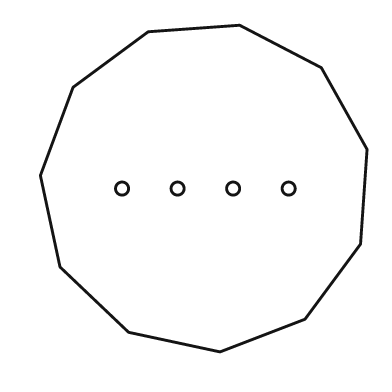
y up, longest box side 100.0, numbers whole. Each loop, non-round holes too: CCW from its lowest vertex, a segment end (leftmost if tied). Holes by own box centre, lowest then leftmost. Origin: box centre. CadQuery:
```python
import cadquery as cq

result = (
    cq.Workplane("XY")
    .moveTo(5.0, -50.0)
    .lineTo(31.0, -40.0)
    .lineTo(48.0, -17.0)
    .lineTo(50.0, 12.0)
    .lineTo(36.0, 37.0)
    .lineTo(11.0, 50.0)
    .lineTo(-17.0, 48.0)
    .lineTo(-40.0, 31.0)
    .lineTo(-50.0, 4.0)
    .lineTo(-44.0, -24.0)
    .lineTo(-23.0, -44.0)
    .close()
    .moveTo(-25.0, 0.0)
    .circle(2.0)
    .moveTo(-8.0, 0.0)
    .circle(2.0)
    .moveTo(9.0, 0.0)
    .circle(2.0)
    .moveTo(26.0, 0.0)
    .circle(2.0)
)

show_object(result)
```